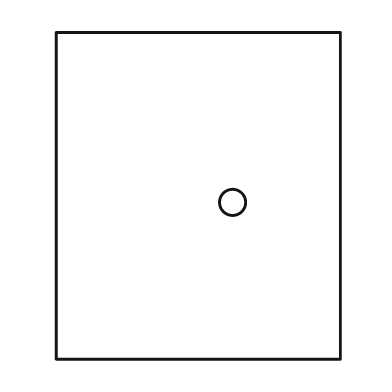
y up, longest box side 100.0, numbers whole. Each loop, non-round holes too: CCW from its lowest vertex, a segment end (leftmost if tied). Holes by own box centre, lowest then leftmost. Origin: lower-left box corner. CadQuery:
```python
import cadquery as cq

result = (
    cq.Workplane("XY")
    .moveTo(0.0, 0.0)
    .lineTo(87.0, 0.0)
    .lineTo(87.0, 100.0)
    .lineTo(0.0, 100.0)
    .close()
    .moveTo(54.0, 48.0)
    .circle(4.0)
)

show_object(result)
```